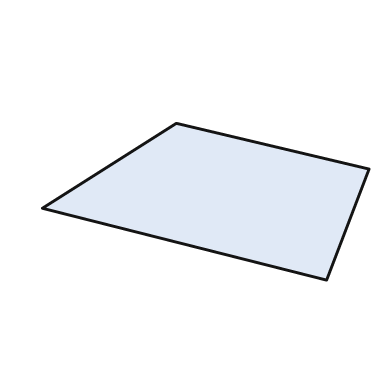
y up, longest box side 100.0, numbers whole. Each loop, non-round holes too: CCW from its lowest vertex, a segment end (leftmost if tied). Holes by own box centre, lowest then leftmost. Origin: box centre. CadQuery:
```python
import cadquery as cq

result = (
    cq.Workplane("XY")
    .moveTo(37.0, -24.0)
    .lineTo(50.0, 10.0)
    .lineTo(-9.0, 24.0)
    .lineTo(-50.0, -2.0)
    .close()
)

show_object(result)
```